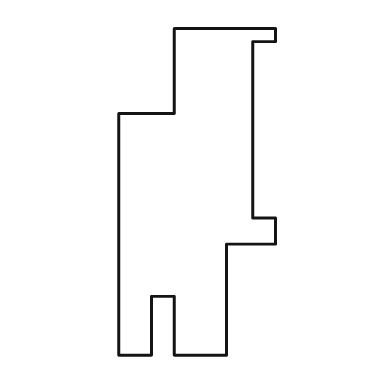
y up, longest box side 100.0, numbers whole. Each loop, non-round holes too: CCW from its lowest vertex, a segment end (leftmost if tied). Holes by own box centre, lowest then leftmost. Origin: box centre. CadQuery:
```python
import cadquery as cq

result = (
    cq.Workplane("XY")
    .moveTo(-24.0, -50.0)
    .lineTo(-14.0, -50.0)
    .lineTo(-14.0, -32.0)
    .lineTo(-7.0, -32.0)
    .lineTo(-7.0, -50.0)
    .lineTo(9.0, -50.0)
    .lineTo(9.0, -16.0)
    .lineTo(24.0, -16.0)
    .lineTo(24.0, -8.0)
    .lineTo(17.0, -8.0)
    .lineTo(17.0, 46.0)
    .lineTo(24.0, 46.0)
    .lineTo(24.0, 50.0)
    .lineTo(-7.0, 50.0)
    .lineTo(-7.0, 24.0)
    .lineTo(-24.0, 24.0)
    .close()
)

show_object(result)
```